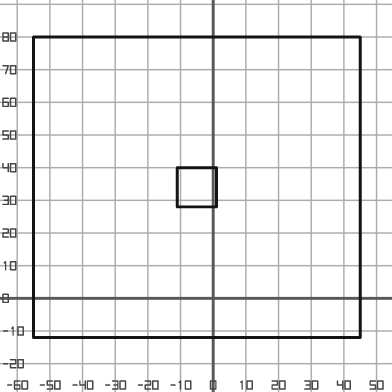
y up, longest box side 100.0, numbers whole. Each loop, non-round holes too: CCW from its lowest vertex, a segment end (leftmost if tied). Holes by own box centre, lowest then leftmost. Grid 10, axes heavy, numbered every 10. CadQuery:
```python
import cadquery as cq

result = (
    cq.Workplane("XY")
    .moveTo(-55.0, -12.0)
    .lineTo(45.0, -12.0)
    .lineTo(45.0, 80.0)
    .lineTo(-55.0, 80.0)
    .close()
    .moveTo(-11.0, 28.0)
    .lineTo(1.0, 28.0)
    .lineTo(1.0, 40.0)
    .lineTo(-11.0, 40.0)
    .close()
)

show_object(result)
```